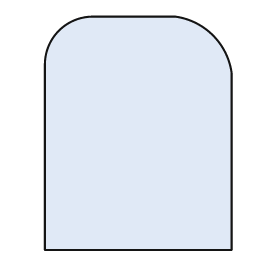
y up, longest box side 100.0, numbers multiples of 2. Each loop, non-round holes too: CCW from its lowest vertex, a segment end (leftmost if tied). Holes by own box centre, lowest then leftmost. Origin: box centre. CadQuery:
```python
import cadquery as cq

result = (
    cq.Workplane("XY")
    .moveTo(-40.0, -50.0)
    .lineTo(40.0, -50.0)
    .lineTo(40.0, 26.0)
    .threePointArc((32.0, 42.0), (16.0, 50.0))
    .lineTo(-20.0, 50.0)
    .threePointArc((-34.0, 44.0), (-40.0, 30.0))
    .close()
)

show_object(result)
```